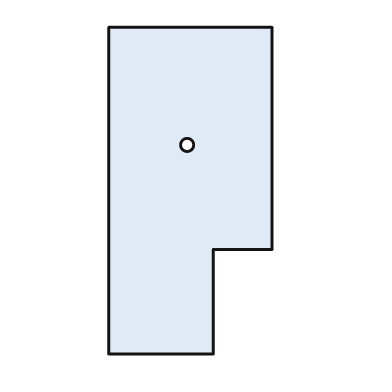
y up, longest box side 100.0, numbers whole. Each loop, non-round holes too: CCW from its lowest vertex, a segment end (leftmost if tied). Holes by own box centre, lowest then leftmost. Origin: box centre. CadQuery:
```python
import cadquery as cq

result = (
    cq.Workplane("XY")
    .moveTo(-25.0, -50.0)
    .lineTo(7.0, -50.0)
    .lineTo(7.0, -18.0)
    .lineTo(25.0, -18.0)
    .lineTo(25.0, 50.0)
    .lineTo(-25.0, 50.0)
    .close()
    .moveTo(-1.0, 14.0)
    .circle(2.0)
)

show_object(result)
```